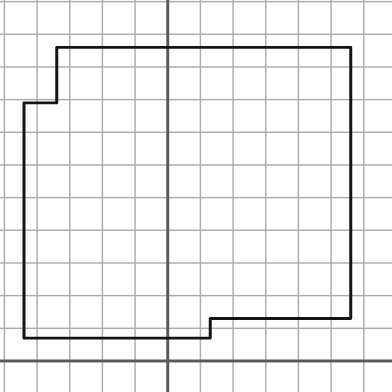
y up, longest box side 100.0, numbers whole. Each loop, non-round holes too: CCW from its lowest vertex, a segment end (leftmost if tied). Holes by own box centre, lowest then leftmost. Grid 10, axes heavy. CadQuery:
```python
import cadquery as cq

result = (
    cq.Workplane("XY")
    .moveTo(-44.0, 7.0)
    .lineTo(13.0, 7.0)
    .lineTo(13.0, 13.0)
    .lineTo(56.0, 13.0)
    .lineTo(56.0, 96.0)
    .lineTo(-34.0, 96.0)
    .lineTo(-34.0, 79.0)
    .lineTo(-44.0, 79.0)
    .close()
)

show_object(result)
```